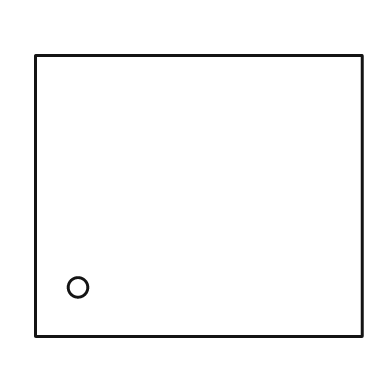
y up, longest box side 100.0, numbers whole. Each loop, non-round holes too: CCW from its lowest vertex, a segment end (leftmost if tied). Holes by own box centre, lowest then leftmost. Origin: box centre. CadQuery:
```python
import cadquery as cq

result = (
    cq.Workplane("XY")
    .moveTo(-50.0, -43.0)
    .lineTo(50.0, -43.0)
    .lineTo(50.0, 43.0)
    .lineTo(-50.0, 43.0)
    .close()
    .moveTo(-37.0, -28.0)
    .circle(3.0)
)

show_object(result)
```